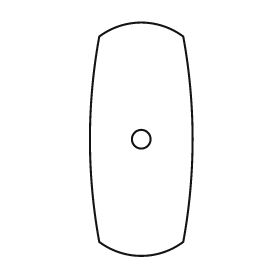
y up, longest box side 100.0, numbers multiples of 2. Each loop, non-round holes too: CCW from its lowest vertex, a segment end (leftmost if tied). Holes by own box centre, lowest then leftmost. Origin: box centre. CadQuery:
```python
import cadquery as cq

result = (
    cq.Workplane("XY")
    .moveTo(-18.0, -44.0)
    .threePointArc((0.0, -50.0), (18.0, -44.0))
    .threePointArc((22.0, 0.0), (18.0, 44.0))
    .threePointArc((0.0, 50.0), (-18.0, 44.0))
    .threePointArc((-22.0, 0.0), (-18.0, -44.0))
    .close()
    .moveTo(0.0, 0.0)
    .circle(4.0)
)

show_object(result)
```